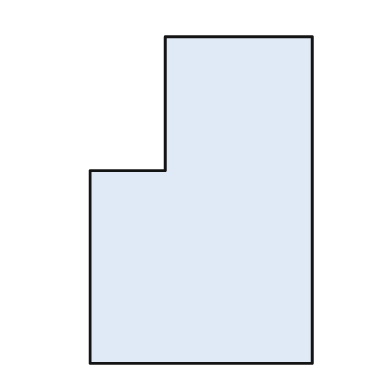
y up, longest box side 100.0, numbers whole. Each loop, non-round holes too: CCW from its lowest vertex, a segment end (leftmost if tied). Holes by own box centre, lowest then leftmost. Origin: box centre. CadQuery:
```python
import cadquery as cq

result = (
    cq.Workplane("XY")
    .moveTo(-34.0, -50.0)
    .lineTo(34.0, -50.0)
    .lineTo(34.0, 50.0)
    .lineTo(-11.0, 50.0)
    .lineTo(-11.0, 9.0)
    .lineTo(-34.0, 9.0)
    .close()
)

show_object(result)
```